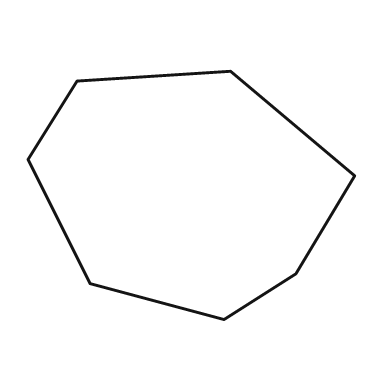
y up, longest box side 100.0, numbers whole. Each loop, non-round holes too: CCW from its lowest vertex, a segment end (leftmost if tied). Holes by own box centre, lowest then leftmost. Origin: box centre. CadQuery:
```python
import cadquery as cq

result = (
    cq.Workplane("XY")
    .moveTo(10.0, -38.0)
    .lineTo(32.0, -24.0)
    .lineTo(50.0, 6.0)
    .lineTo(12.0, 38.0)
    .lineTo(-35.0, 35.0)
    .lineTo(-50.0, 11.0)
    .lineTo(-31.0, -27.0)
    .close()
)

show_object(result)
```